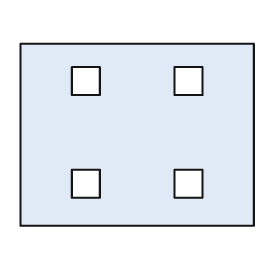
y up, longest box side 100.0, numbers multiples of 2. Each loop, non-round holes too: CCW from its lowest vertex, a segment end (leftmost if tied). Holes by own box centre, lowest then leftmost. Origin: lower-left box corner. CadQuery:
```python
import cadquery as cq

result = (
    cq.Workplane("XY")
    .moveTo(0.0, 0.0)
    .lineTo(100.0, 0.0)
    .lineTo(100.0, 78.0)
    .lineTo(0.0, 78.0)
    .close()
    .moveTo(22.0, 12.0)
    .lineTo(34.0, 12.0)
    .lineTo(34.0, 24.0)
    .lineTo(22.0, 24.0)
    .close()
    .moveTo(66.0, 12.0)
    .lineTo(78.0, 12.0)
    .lineTo(78.0, 24.0)
    .lineTo(66.0, 24.0)
    .close()
    .moveTo(22.0, 56.0)
    .lineTo(34.0, 56.0)
    .lineTo(34.0, 68.0)
    .lineTo(22.0, 68.0)
    .close()
    .moveTo(66.0, 56.0)
    .lineTo(78.0, 56.0)
    .lineTo(78.0, 68.0)
    .lineTo(66.0, 68.0)
    .close()
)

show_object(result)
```